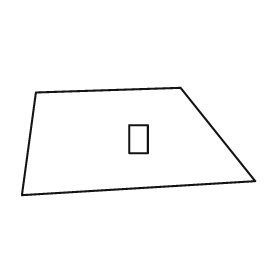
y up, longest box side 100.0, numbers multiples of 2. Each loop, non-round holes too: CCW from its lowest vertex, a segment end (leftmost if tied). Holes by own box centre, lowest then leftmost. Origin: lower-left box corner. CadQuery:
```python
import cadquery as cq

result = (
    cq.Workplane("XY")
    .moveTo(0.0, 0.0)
    .lineTo(100.0, 6.0)
    .lineTo(68.0, 46.0)
    .lineTo(6.0, 44.0)
    .close()
    .moveTo(46.0, 18.0)
    .lineTo(54.0, 18.0)
    .lineTo(54.0, 30.0)
    .lineTo(46.0, 30.0)
    .close()
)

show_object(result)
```